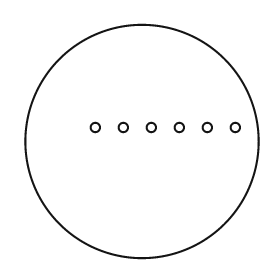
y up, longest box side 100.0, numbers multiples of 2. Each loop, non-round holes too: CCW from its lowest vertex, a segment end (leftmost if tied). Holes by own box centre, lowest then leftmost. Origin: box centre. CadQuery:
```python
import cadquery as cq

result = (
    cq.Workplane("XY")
    .moveTo(0.0, 0.0)
    .circle(50.0)
    .moveTo(-20.0, 6.0)
    .circle(2.0)
    .moveTo(-8.0, 6.0)
    .circle(2.0)
    .moveTo(4.0, 6.0)
    .circle(2.0)
    .moveTo(16.0, 6.0)
    .circle(2.0)
    .moveTo(28.0, 6.0)
    .circle(2.0)
    .moveTo(40.0, 6.0)
    .circle(2.0)
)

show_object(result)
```